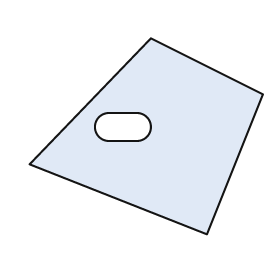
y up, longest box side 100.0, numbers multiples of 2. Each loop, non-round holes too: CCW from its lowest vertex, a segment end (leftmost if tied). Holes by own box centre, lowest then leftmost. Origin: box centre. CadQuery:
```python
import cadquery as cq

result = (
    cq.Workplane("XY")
    .moveTo(26.0, -42.0)
    .lineTo(50.0, 18.0)
    .lineTo(2.0, 42.0)
    .lineTo(-50.0, -12.0)
    .close()
    .moveTo(-16.0, -2.0)
    .lineTo(-4.0, -2.0)
    .threePointArc((2.0, 4.0), (-4.0, 10.0))
    .lineTo(-16.0, 10.0)
    .threePointArc((-22.0, 4.0), (-16.0, -2.0))
    .close()
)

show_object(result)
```